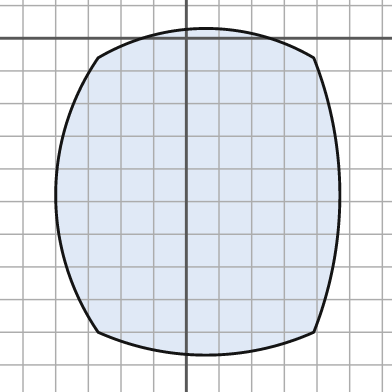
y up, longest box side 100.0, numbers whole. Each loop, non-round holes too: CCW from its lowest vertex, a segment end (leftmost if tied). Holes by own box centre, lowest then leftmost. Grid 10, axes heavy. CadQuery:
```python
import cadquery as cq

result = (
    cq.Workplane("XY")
    .moveTo(-27.0, -90.0)
    .threePointArc((6.0, -97.0), (39.0, -90.0))
    .threePointArc((47.0, -48.0), (39.0, -6.0))
    .threePointArc((6.0, 3.0), (-27.0, -6.0))
    .threePointArc((-40.0, -48.0), (-27.0, -90.0))
    .close()
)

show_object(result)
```